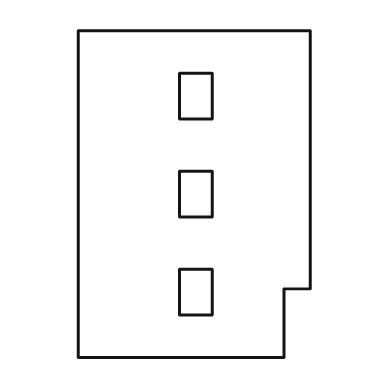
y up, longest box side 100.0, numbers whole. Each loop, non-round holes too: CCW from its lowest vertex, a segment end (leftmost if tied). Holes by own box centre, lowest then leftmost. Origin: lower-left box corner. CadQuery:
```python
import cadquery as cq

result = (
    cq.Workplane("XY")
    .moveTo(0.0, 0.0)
    .lineTo(63.0, 0.0)
    .lineTo(63.0, 21.0)
    .lineTo(71.0, 21.0)
    .lineTo(71.0, 100.0)
    .lineTo(0.0, 100.0)
    .close()
    .moveTo(31.0, 13.0)
    .lineTo(41.0, 13.0)
    .lineTo(41.0, 27.0)
    .lineTo(31.0, 27.0)
    .close()
    .moveTo(31.0, 43.0)
    .lineTo(41.0, 43.0)
    .lineTo(41.0, 57.0)
    .lineTo(31.0, 57.0)
    .close()
    .moveTo(31.0, 73.0)
    .lineTo(41.0, 73.0)
    .lineTo(41.0, 87.0)
    .lineTo(31.0, 87.0)
    .close()
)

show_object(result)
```